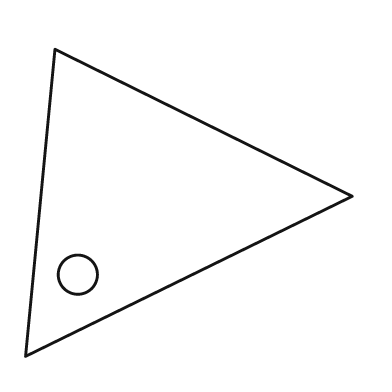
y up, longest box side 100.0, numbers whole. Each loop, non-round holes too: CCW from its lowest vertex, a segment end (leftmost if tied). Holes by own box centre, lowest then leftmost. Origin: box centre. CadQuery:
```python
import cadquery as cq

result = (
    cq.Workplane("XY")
    .moveTo(-50.0, -47.0)
    .lineTo(50.0, 2.0)
    .lineTo(-41.0, 47.0)
    .close()
    .moveTo(-34.0, -22.0)
    .circle(6.0)
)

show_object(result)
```